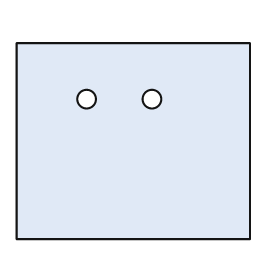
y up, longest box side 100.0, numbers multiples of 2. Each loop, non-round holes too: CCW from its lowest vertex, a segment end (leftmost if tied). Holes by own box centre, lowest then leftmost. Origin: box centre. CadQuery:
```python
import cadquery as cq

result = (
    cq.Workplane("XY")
    .moveTo(-50.0, -42.0)
    .lineTo(50.0, -42.0)
    .lineTo(50.0, 42.0)
    .lineTo(-50.0, 42.0)
    .close()
    .moveTo(-20.0, 18.0)
    .circle(4.0)
    .moveTo(8.0, 18.0)
    .circle(4.0)
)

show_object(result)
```